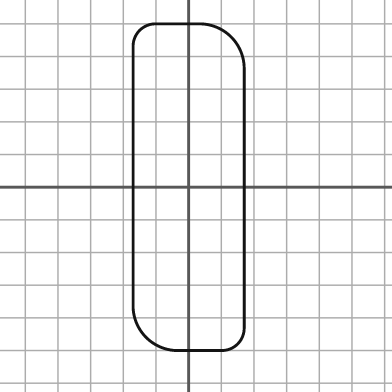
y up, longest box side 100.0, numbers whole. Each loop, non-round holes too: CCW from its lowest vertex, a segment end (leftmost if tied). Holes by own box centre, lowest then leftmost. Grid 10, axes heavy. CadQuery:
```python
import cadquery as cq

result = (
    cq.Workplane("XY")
    .moveTo(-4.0, -50.0)
    .lineTo(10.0, -50.0)
    .threePointArc((15.0, -48.0), (17.0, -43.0))
    .lineTo(17.0, 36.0)
    .threePointArc((13.0, 46.0), (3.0, 50.0))
    .lineTo(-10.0, 50.0)
    .threePointArc((-15.0, 48.0), (-17.0, 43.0))
    .lineTo(-17.0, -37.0)
    .threePointArc((-13.0, -46.0), (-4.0, -50.0))
    .close()
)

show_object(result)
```